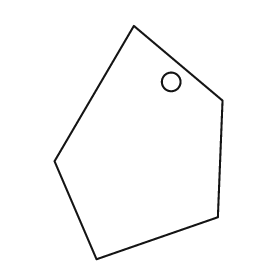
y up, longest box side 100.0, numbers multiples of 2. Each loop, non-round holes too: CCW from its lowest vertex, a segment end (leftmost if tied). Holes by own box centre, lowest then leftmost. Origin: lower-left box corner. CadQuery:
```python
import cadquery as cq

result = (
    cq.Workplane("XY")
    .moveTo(18.0, 0.0)
    .lineTo(70.0, 18.0)
    .lineTo(72.0, 68.0)
    .lineTo(34.0, 100.0)
    .lineTo(0.0, 42.0)
    .close()
    .moveTo(50.0, 76.0)
    .circle(4.0)
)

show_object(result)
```